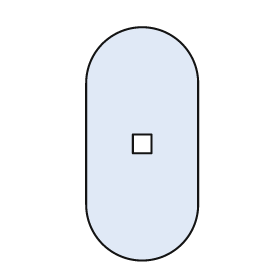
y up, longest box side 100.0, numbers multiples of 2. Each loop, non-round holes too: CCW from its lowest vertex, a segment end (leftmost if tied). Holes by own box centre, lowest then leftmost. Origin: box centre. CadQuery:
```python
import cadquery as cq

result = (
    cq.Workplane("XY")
    .moveTo(-24.0, -26.0)
    .threePointArc((0.0, -50.0), (24.0, -26.0))
    .lineTo(24.0, 26.0)
    .threePointArc((0.0, 50.0), (-24.0, 26.0))
    .close()
    .moveTo(-4.0, -4.0)
    .lineTo(4.0, -4.0)
    .lineTo(4.0, 4.0)
    .lineTo(-4.0, 4.0)
    .close()
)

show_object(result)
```